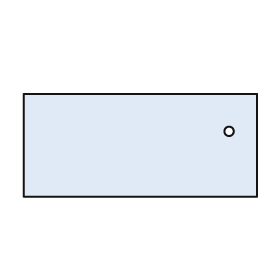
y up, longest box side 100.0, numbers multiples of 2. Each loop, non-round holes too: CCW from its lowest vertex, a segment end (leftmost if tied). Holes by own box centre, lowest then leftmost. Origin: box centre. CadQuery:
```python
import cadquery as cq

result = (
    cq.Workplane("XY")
    .moveTo(-50.0, -22.0)
    .lineTo(50.0, -22.0)
    .lineTo(50.0, 22.0)
    .lineTo(-50.0, 22.0)
    .close()
    .moveTo(38.0, 6.0)
    .circle(2.0)
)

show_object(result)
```